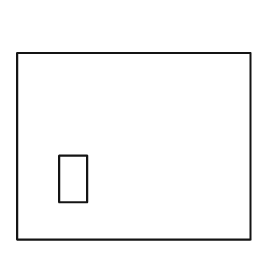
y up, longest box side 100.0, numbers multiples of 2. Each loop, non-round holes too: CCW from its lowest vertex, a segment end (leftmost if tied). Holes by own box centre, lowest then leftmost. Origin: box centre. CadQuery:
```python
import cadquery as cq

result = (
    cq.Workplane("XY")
    .moveTo(-50.0, -40.0)
    .lineTo(50.0, -40.0)
    .lineTo(50.0, 40.0)
    .lineTo(-50.0, 40.0)
    .close()
    .moveTo(-32.0, -24.0)
    .lineTo(-20.0, -24.0)
    .lineTo(-20.0, -4.0)
    .lineTo(-32.0, -4.0)
    .close()
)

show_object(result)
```